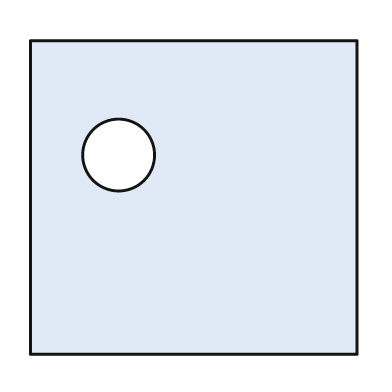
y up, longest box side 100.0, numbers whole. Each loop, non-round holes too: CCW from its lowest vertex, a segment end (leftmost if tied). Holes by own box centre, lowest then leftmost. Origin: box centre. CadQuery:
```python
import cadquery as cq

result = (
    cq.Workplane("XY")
    .moveTo(-50.0, -48.0)
    .lineTo(50.0, -48.0)
    .lineTo(50.0, 48.0)
    .lineTo(-50.0, 48.0)
    .close()
    .moveTo(-23.0, 13.0)
    .circle(11.0)
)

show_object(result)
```